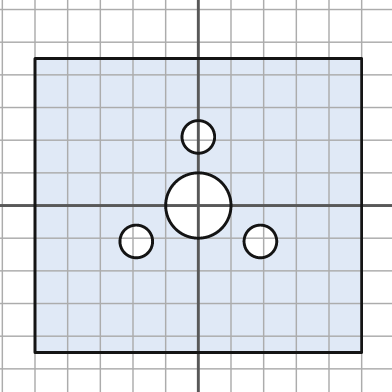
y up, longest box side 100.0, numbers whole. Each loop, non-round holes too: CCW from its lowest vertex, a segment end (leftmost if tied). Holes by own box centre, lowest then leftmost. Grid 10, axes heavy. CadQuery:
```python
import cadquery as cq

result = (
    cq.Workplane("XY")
    .moveTo(-50.0, -45.0)
    .lineTo(50.0, -45.0)
    .lineTo(50.0, 45.0)
    .lineTo(-50.0, 45.0)
    .close()
    .moveTo(-19.0, -11.0)
    .circle(5.0)
    .moveTo(19.0, -11.0)
    .circle(5.0)
    .moveTo(0.0, 0.0)
    .circle(10.0)
    .moveTo(0.0, 21.0)
    .circle(5.0)
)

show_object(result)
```